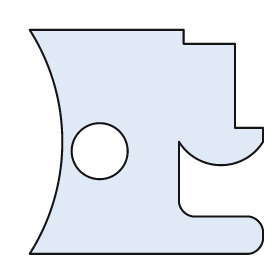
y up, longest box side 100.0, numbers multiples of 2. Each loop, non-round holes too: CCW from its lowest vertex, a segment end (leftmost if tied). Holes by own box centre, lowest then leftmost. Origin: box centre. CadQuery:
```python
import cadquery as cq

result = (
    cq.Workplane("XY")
    .moveTo(-50.0, -48.0)
    .lineTo(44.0, -48.0)
    .threePointArc((48.0, -46.0), (50.0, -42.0))
    .lineTo(50.0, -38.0)
    .threePointArc((48.0, -34.0), (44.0, -32.0))
    .lineTo(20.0, -32.0)
    .threePointArc((16.0, -30.0), (14.0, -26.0))
    .lineTo(14.0, 0.0)
    .threePointArc((32.0, -10.0), (50.0, 0.0))
    .lineTo(50.0, 6.0)
    .lineTo(38.0, 6.0)
    .lineTo(38.0, 42.0)
    .lineTo(16.0, 42.0)
    .lineTo(16.0, 48.0)
    .lineTo(-50.0, 48.0)
    .threePointArc((-36.0, 0.0), (-50.0, -48.0))
    .close()
    .moveTo(-20.0, -4.0)
    .circle(12.0)
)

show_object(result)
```